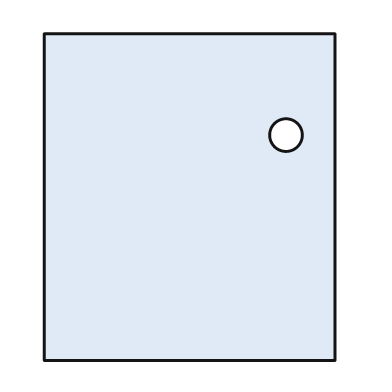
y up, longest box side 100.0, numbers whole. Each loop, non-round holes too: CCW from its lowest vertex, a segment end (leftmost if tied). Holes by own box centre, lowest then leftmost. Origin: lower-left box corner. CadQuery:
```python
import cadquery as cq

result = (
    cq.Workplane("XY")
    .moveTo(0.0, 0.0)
    .lineTo(89.0, 0.0)
    .lineTo(89.0, 100.0)
    .lineTo(0.0, 100.0)
    .close()
    .moveTo(74.0, 69.0)
    .circle(5.0)
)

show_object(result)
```